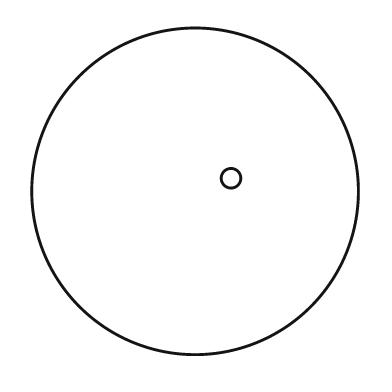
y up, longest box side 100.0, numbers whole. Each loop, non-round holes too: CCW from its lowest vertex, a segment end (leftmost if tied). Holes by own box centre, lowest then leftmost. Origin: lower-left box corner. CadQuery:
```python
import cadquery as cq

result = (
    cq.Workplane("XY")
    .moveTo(50.0, 50.0)
    .circle(50.0)
    .moveTo(61.0, 54.0)
    .circle(3.0)
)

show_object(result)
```